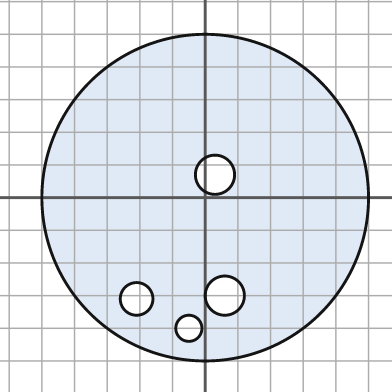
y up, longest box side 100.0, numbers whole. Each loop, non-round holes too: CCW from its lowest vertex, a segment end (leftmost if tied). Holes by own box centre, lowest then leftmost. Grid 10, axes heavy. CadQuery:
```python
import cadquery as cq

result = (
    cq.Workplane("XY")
    .moveTo(0.0, 0.0)
    .circle(50.0)
    .moveTo(-5.0, -40.0)
    .circle(4.0)
    .moveTo(-21.0, -31.0)
    .circle(5.0)
    .moveTo(6.0, -30.0)
    .circle(6.0)
    .moveTo(3.0, 7.0)
    .circle(6.0)
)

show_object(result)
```